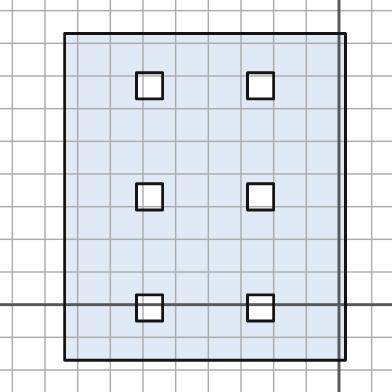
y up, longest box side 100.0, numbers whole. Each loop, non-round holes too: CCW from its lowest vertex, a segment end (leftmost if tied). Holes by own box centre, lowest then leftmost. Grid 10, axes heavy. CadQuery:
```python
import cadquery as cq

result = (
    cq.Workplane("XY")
    .moveTo(-84.0, -17.0)
    .lineTo(2.0, -17.0)
    .lineTo(2.0, 83.0)
    .lineTo(-84.0, 83.0)
    .close()
    .moveTo(-62.0, -5.0)
    .lineTo(-54.0, -5.0)
    .lineTo(-54.0, 3.0)
    .lineTo(-62.0, 3.0)
    .close()
    .moveTo(-28.0, -5.0)
    .lineTo(-20.0, -5.0)
    .lineTo(-20.0, 3.0)
    .lineTo(-28.0, 3.0)
    .close()
    .moveTo(-62.0, 29.0)
    .lineTo(-54.0, 29.0)
    .lineTo(-54.0, 37.0)
    .lineTo(-62.0, 37.0)
    .close()
    .moveTo(-28.0, 29.0)
    .lineTo(-20.0, 29.0)
    .lineTo(-20.0, 37.0)
    .lineTo(-28.0, 37.0)
    .close()
    .moveTo(-62.0, 63.0)
    .lineTo(-54.0, 63.0)
    .lineTo(-54.0, 71.0)
    .lineTo(-62.0, 71.0)
    .close()
    .moveTo(-28.0, 63.0)
    .lineTo(-20.0, 63.0)
    .lineTo(-20.0, 71.0)
    .lineTo(-28.0, 71.0)
    .close()
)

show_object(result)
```